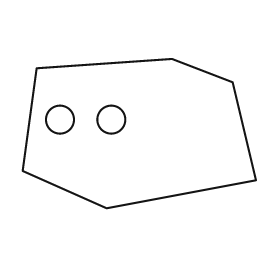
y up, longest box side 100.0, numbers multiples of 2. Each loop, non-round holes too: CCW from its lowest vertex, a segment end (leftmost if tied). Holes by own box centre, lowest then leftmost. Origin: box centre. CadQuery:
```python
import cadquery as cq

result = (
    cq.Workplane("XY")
    .moveTo(-14.0, -32.0)
    .lineTo(50.0, -20.0)
    .lineTo(40.0, 22.0)
    .lineTo(14.0, 32.0)
    .lineTo(-44.0, 28.0)
    .lineTo(-50.0, -16.0)
    .close()
    .moveTo(-34.0, 6.0)
    .circle(6.0)
    .moveTo(-12.0, 6.0)
    .circle(6.0)
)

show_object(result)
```